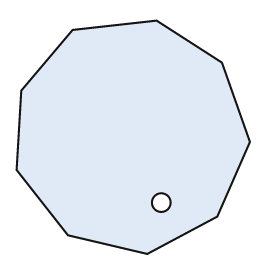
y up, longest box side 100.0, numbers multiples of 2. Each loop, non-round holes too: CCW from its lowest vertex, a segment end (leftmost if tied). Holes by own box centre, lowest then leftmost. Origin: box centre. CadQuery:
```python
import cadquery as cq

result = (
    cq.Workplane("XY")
    .moveTo(6.0, -50.0)
    .lineTo(36.0, -34.0)
    .lineTo(50.0, -2.0)
    .lineTo(38.0, 32.0)
    .lineTo(10.0, 50.0)
    .lineTo(-26.0, 46.0)
    .lineTo(-48.0, 20.0)
    .lineTo(-50.0, -14.0)
    .lineTo(-28.0, -42.0)
    .close()
    .moveTo(12.0, -28.0)
    .circle(4.0)
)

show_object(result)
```